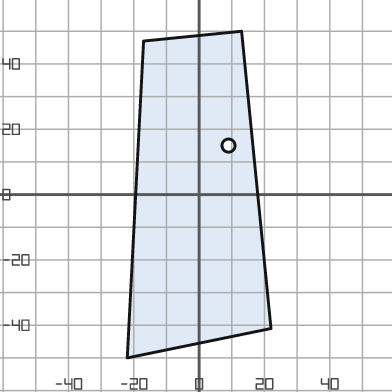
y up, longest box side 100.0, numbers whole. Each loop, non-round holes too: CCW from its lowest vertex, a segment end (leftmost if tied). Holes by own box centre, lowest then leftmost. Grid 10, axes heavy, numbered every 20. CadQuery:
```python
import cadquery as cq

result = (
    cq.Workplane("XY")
    .moveTo(-22.0, -50.0)
    .lineTo(22.0, -41.0)
    .lineTo(13.0, 50.0)
    .lineTo(-17.0, 47.0)
    .close()
    .moveTo(9.0, 15.0)
    .circle(2.0)
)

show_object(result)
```